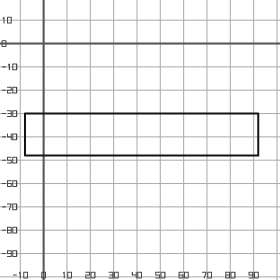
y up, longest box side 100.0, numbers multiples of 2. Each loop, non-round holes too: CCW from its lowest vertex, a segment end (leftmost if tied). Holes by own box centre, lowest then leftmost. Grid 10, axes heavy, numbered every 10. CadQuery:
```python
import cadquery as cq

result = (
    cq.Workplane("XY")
    .moveTo(-8.0, -48.0)
    .lineTo(92.0, -48.0)
    .lineTo(92.0, -30.0)
    .lineTo(-8.0, -30.0)
    .close()
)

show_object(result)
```